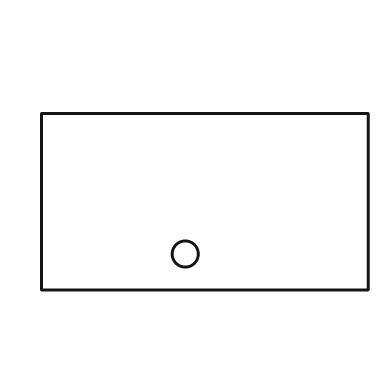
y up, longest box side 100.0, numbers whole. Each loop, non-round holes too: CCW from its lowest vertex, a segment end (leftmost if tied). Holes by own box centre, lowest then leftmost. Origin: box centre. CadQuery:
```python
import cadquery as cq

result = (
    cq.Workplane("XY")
    .moveTo(-50.0, -27.0)
    .lineTo(50.0, -27.0)
    .lineTo(50.0, 27.0)
    .lineTo(-50.0, 27.0)
    .close()
    .moveTo(-6.0, -16.0)
    .circle(4.0)
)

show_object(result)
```